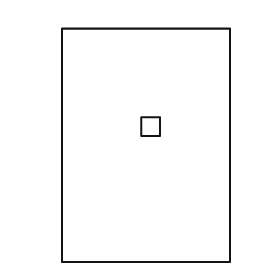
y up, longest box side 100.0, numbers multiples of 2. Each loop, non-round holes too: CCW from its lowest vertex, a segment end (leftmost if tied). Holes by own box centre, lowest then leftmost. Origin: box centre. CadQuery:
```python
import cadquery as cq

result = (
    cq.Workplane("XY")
    .moveTo(-36.0, -50.0)
    .lineTo(36.0, -50.0)
    .lineTo(36.0, 50.0)
    .lineTo(-36.0, 50.0)
    .close()
    .moveTo(-2.0, 4.0)
    .lineTo(6.0, 4.0)
    .lineTo(6.0, 12.0)
    .lineTo(-2.0, 12.0)
    .close()
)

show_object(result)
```